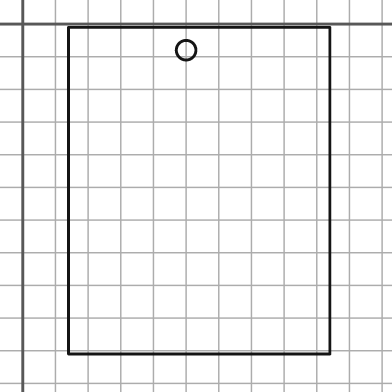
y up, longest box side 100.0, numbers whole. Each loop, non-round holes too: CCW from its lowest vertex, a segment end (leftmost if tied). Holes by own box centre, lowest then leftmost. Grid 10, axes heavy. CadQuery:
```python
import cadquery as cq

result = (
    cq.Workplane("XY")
    .moveTo(14.0, -101.0)
    .lineTo(94.0, -101.0)
    .lineTo(94.0, -1.0)
    .lineTo(14.0, -1.0)
    .close()
    .moveTo(50.0, -8.0)
    .circle(3.0)
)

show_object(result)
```